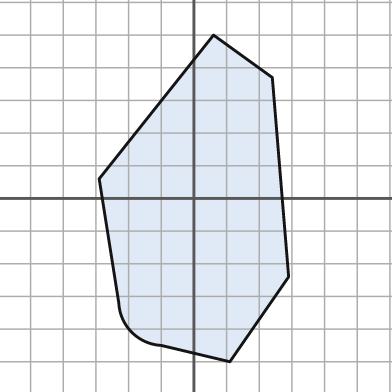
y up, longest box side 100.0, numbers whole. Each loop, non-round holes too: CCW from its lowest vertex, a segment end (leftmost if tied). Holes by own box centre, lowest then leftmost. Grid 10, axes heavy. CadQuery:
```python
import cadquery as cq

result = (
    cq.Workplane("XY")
    .moveTo(11.0, -50.0)
    .lineTo(29.0, -24.0)
    .lineTo(24.0, 37.0)
    .lineTo(6.0, 50.0)
    .lineTo(-29.0, 6.0)
    .lineTo(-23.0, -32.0)
    .threePointArc((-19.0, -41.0), (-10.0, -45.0))
    .close()
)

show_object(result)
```